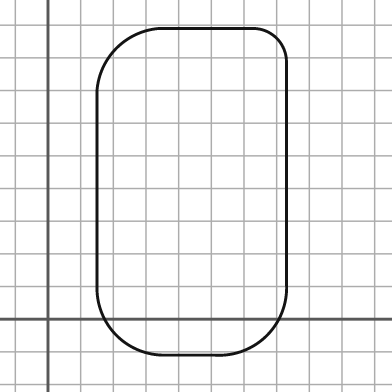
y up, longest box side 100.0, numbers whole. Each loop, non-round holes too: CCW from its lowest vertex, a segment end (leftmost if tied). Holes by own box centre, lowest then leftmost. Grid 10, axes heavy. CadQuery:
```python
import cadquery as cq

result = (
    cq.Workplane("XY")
    .moveTo(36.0, -11.0)
    .lineTo(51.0, -11.0)
    .threePointArc((67.0, -5.0), (73.0, 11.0))
    .lineTo(73.0, 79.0)
    .threePointArc((70.0, 86.0), (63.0, 89.0))
    .lineTo(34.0, 89.0)
    .threePointArc((21.0, 83.0), (15.0, 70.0))
    .lineTo(15.0, 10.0)
    .threePointArc((21.0, -5.0), (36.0, -11.0))
    .close()
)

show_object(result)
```